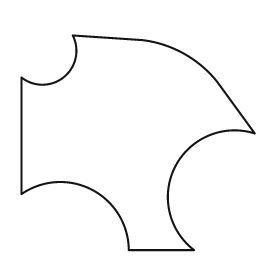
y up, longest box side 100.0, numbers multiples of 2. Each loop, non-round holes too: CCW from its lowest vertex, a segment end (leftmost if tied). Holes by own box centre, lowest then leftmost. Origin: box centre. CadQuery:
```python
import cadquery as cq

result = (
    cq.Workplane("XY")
    .moveTo(-4.0, -46.0)
    .lineTo(24.0, -46.0)
    .threePointArc((16.0, -10.0), (50.0, 4.0))
    .lineTo(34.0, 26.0)
    .threePointArc((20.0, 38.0), (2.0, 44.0))
    .lineTo(-28.0, 46.0)
    .threePointArc((-32.0, 28.0), (-50.0, 28.0))
    .lineTo(-50.0, -22.0)
    .threePointArc((-20.0, -20.0), (-4.0, -46.0))
    .close()
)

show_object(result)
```